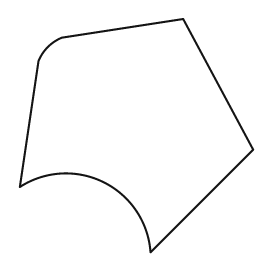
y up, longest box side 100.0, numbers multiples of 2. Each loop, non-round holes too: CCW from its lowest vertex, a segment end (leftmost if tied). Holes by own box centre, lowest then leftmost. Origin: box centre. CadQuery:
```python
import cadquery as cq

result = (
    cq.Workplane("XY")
    .moveTo(6.0, -50.0)
    .lineTo(50.0, -6.0)
    .lineTo(20.0, 50.0)
    .lineTo(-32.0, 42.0)
    .threePointArc((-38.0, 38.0), (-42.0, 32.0))
    .lineTo(-50.0, -22.0)
    .threePointArc((-14.0, -20.0), (6.0, -50.0))
    .close()
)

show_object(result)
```